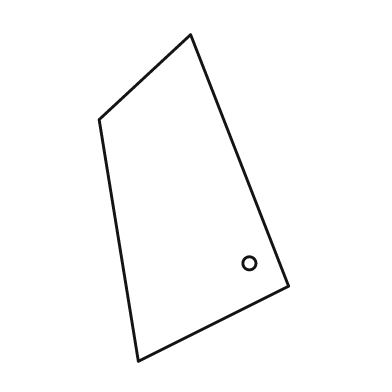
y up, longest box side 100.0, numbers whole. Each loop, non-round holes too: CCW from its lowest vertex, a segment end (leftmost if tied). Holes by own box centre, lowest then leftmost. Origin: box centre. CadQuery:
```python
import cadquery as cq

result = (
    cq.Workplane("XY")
    .moveTo(-17.0, -50.0)
    .lineTo(29.0, -27.0)
    .lineTo(-1.0, 50.0)
    .lineTo(-29.0, 24.0)
    .close()
    .moveTo(17.0, -20.0)
    .circle(2.0)
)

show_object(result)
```